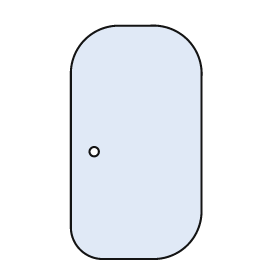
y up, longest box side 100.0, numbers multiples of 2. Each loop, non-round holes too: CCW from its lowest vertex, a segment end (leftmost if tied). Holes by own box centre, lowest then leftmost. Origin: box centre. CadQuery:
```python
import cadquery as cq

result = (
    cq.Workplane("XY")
    .moveTo(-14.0, -50.0)
    .lineTo(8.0, -50.0)
    .threePointArc((22.0, -44.0), (28.0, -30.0))
    .lineTo(28.0, 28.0)
    .threePointArc((22.0, 44.0), (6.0, 50.0))
    .lineTo(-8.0, 50.0)
    .threePointArc((-22.0, 44.0), (-28.0, 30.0))
    .lineTo(-28.0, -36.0)
    .threePointArc((-24.0, -46.0), (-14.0, -50.0))
    .close()
    .moveTo(-18.0, -4.0)
    .circle(2.0)
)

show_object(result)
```